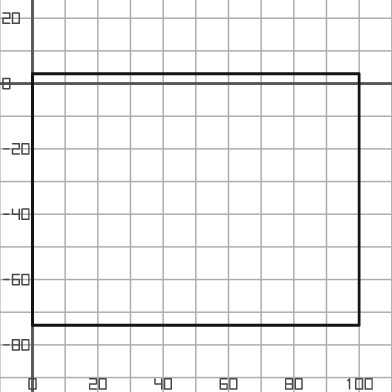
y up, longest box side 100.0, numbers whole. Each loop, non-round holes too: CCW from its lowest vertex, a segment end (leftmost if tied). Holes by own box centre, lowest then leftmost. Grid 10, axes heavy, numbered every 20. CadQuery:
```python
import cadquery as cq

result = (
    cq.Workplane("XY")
    .moveTo(0.0, -74.0)
    .lineTo(100.0, -74.0)
    .lineTo(100.0, 3.0)
    .lineTo(0.0, 3.0)
    .close()
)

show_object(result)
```